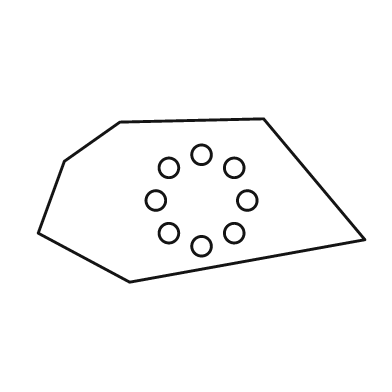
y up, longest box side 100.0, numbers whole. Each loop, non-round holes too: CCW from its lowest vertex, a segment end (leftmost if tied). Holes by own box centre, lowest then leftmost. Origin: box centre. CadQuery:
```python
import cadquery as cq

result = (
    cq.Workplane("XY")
    .moveTo(-22.0, -25.0)
    .lineTo(50.0, -12.0)
    .lineTo(19.0, 25.0)
    .lineTo(-25.0, 24.0)
    .lineTo(-42.0, 12.0)
    .lineTo(-50.0, -10.0)
    .close()
    .moveTo(0.0, -14.0)
    .circle(3.0)
    .moveTo(-10.0, -10.0)
    .circle(3.0)
    .moveTo(10.0, -10.0)
    .circle(3.0)
    .moveTo(-14.0, 0.0)
    .circle(3.0)
    .moveTo(14.0, 0.0)
    .circle(3.0)
    .moveTo(-10.0, 10.0)
    .circle(3.0)
    .moveTo(10.0, 10.0)
    .circle(3.0)
    .moveTo(0.0, 14.0)
    .circle(3.0)
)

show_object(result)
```